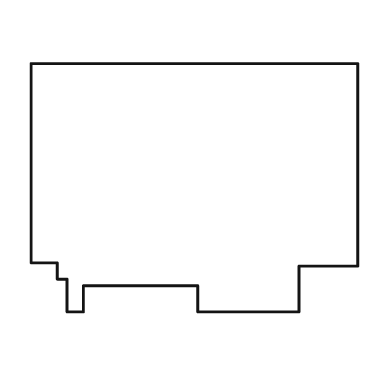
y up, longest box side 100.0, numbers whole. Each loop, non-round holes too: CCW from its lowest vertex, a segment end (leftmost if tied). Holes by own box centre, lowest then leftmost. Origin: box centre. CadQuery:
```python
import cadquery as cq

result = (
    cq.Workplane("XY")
    .moveTo(-39.0, -38.0)
    .lineTo(-34.0, -38.0)
    .lineTo(-34.0, -30.0)
    .lineTo(1.0, -30.0)
    .lineTo(1.0, -38.0)
    .lineTo(32.0, -38.0)
    .lineTo(32.0, -24.0)
    .lineTo(50.0, -24.0)
    .lineTo(50.0, 38.0)
    .lineTo(-50.0, 38.0)
    .lineTo(-50.0, -23.0)
    .lineTo(-42.0, -23.0)
    .lineTo(-42.0, -28.0)
    .lineTo(-39.0, -28.0)
    .close()
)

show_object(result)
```